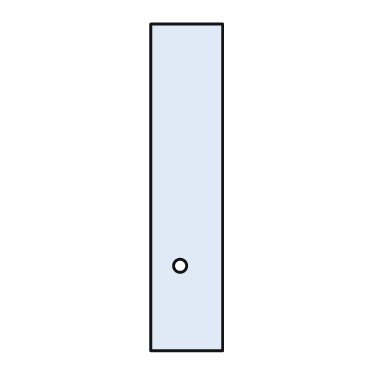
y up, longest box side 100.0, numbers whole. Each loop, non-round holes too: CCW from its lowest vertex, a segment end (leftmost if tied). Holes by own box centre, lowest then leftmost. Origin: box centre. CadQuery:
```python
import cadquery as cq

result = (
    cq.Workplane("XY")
    .moveTo(-11.0, -50.0)
    .lineTo(11.0, -50.0)
    .lineTo(11.0, 50.0)
    .lineTo(-11.0, 50.0)
    .close()
    .moveTo(-2.0, -24.0)
    .circle(2.0)
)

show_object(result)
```